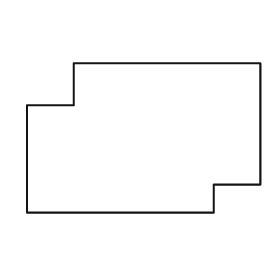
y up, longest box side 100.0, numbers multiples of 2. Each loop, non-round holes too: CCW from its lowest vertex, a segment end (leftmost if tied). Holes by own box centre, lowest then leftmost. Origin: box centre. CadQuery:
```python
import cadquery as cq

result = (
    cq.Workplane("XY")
    .moveTo(-50.0, -32.0)
    .lineTo(30.0, -32.0)
    .lineTo(30.0, -20.0)
    .lineTo(50.0, -20.0)
    .lineTo(50.0, 32.0)
    .lineTo(-30.0, 32.0)
    .lineTo(-30.0, 14.0)
    .lineTo(-50.0, 14.0)
    .close()
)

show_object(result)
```